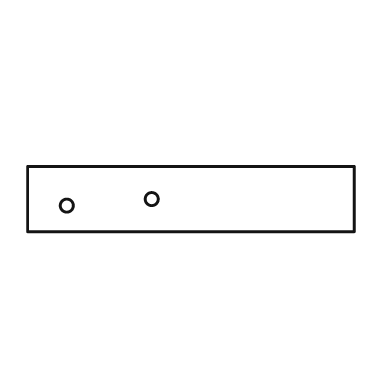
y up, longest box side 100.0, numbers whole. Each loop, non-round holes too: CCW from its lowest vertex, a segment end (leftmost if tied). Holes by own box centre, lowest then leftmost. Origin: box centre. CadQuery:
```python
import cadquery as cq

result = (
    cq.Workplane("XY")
    .moveTo(-50.0, -10.0)
    .lineTo(50.0, -10.0)
    .lineTo(50.0, 10.0)
    .lineTo(-50.0, 10.0)
    .close()
    .moveTo(-38.0, -2.0)
    .circle(2.0)
    .moveTo(-12.0, 0.0)
    .circle(2.0)
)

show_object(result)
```